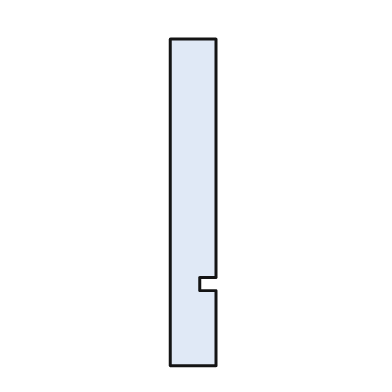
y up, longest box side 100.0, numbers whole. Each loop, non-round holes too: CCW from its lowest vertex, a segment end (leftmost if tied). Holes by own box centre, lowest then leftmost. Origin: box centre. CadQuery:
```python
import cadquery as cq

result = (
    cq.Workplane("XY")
    .moveTo(-7.0, -50.0)
    .lineTo(7.0, -50.0)
    .lineTo(7.0, -27.0)
    .lineTo(2.0, -27.0)
    .lineTo(2.0, -23.0)
    .lineTo(7.0, -23.0)
    .lineTo(7.0, 50.0)
    .lineTo(-7.0, 50.0)
    .close()
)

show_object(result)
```